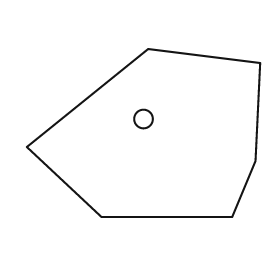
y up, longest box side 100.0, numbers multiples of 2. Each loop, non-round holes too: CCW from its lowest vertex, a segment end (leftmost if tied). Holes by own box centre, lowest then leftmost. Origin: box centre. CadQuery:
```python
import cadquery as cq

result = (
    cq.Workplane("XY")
    .moveTo(-18.0, -36.0)
    .lineTo(38.0, -36.0)
    .lineTo(48.0, -12.0)
    .lineTo(50.0, 30.0)
    .lineTo(2.0, 36.0)
    .lineTo(-50.0, -6.0)
    .close()
    .moveTo(0.0, 6.0)
    .circle(4.0)
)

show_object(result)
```